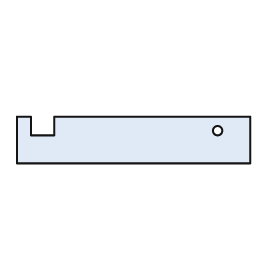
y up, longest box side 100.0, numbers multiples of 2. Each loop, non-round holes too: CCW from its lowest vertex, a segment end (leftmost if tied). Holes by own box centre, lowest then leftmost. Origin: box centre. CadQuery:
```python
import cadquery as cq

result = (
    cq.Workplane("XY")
    .moveTo(-50.0, -10.0)
    .lineTo(50.0, -10.0)
    .lineTo(50.0, 10.0)
    .lineTo(-34.0, 10.0)
    .lineTo(-34.0, 2.0)
    .lineTo(-44.0, 2.0)
    .lineTo(-44.0, 10.0)
    .lineTo(-50.0, 10.0)
    .close()
    .moveTo(36.0, 4.0)
    .circle(2.0)
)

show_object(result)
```